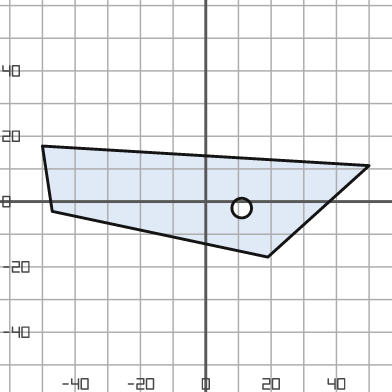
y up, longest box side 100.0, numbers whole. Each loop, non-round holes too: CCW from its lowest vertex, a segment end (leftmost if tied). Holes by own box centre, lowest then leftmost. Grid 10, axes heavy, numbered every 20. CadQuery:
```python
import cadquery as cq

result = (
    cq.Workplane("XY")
    .moveTo(19.0, -17.0)
    .lineTo(50.0, 11.0)
    .lineTo(-50.0, 17.0)
    .lineTo(-47.0, -3.0)
    .close()
    .moveTo(11.0, -2.0)
    .circle(3.0)
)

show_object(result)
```